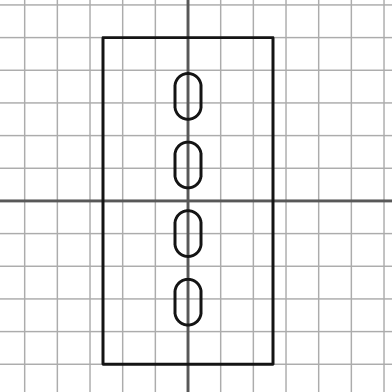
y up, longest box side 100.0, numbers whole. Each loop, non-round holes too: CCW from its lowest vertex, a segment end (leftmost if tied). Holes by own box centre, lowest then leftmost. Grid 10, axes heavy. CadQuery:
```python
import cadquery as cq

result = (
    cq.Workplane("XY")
    .moveTo(-26.0, -50.0)
    .lineTo(26.0, -50.0)
    .lineTo(26.0, 50.0)
    .lineTo(-26.0, 50.0)
    .close()
    .moveTo(-4.0, -34.0)
    .threePointArc((0.0, -38.0), (4.0, -34.0))
    .lineTo(4.0, -28.0)
    .threePointArc((0.0, -24.0), (-4.0, -28.0))
    .close()
    .moveTo(-4.0, -13.0)
    .threePointArc((0.0, -17.0), (4.0, -13.0))
    .lineTo(4.0, -7.0)
    .threePointArc((0.0, -3.0), (-4.0, -7.0))
    .close()
    .moveTo(-4.0, 8.0)
    .threePointArc((0.0, 4.0), (4.0, 8.0))
    .lineTo(4.0, 14.0)
    .threePointArc((0.0, 18.0), (-4.0, 14.0))
    .close()
    .moveTo(-4.0, 29.0)
    .threePointArc((0.0, 25.0), (4.0, 29.0))
    .lineTo(4.0, 35.0)
    .threePointArc((0.0, 39.0), (-4.0, 35.0))
    .close()
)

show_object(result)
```